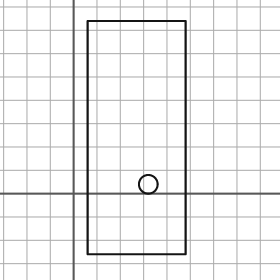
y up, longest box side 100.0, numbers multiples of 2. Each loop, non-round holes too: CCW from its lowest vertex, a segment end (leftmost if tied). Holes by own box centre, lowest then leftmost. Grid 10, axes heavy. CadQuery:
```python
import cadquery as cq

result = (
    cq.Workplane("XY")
    .moveTo(6.0, -26.0)
    .lineTo(48.0, -26.0)
    .lineTo(48.0, 74.0)
    .lineTo(6.0, 74.0)
    .close()
    .moveTo(32.0, 4.0)
    .circle(4.0)
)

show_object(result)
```